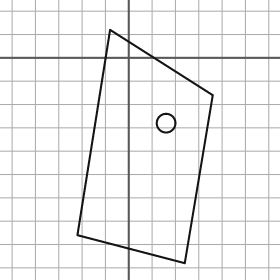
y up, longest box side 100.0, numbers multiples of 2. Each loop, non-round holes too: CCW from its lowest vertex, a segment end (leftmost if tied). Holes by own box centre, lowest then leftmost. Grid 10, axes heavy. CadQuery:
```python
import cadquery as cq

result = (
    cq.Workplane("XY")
    .moveTo(24.0, -88.0)
    .lineTo(36.0, -16.0)
    .lineTo(-8.0, 12.0)
    .lineTo(-22.0, -76.0)
    .close()
    .moveTo(16.0, -28.0)
    .circle(4.0)
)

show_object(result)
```